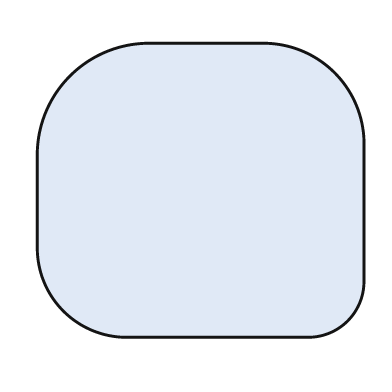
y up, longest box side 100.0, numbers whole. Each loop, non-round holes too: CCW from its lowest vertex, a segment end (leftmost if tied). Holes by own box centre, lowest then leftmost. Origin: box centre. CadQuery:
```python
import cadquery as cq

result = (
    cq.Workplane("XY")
    .moveTo(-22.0, -45.0)
    .lineTo(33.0, -45.0)
    .threePointArc((45.0, -40.0), (50.0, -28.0))
    .lineTo(50.0, 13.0)
    .threePointArc((41.0, 36.0), (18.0, 45.0))
    .lineTo(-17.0, 45.0)
    .threePointArc((-40.0, 35.0), (-50.0, 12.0))
    .lineTo(-50.0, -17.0)
    .threePointArc((-42.0, -37.0), (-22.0, -45.0))
    .close()
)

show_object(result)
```